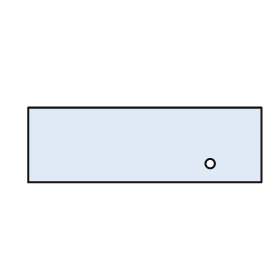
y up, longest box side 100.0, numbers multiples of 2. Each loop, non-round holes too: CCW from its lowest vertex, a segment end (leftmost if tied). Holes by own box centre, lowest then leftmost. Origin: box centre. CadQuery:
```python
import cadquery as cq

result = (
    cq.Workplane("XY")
    .moveTo(-50.0, -16.0)
    .lineTo(50.0, -16.0)
    .lineTo(50.0, 16.0)
    .lineTo(-50.0, 16.0)
    .close()
    .moveTo(28.0, -8.0)
    .circle(2.0)
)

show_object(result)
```